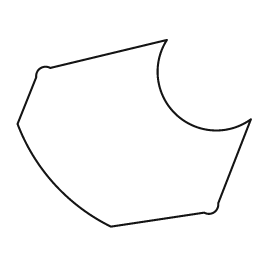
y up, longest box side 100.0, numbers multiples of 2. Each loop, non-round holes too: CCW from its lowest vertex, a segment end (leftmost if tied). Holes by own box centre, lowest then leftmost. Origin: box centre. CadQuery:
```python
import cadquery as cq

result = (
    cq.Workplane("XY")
    .moveTo(-10.0, -40.0)
    .lineTo(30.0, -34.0)
    .threePointArc((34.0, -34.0), (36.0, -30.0))
    .lineTo(50.0, 6.0)
    .threePointArc((18.0, 8.0), (14.0, 40.0))
    .lineTo(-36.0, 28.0)
    .threePointArc((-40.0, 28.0), (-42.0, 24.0))
    .lineTo(-50.0, 4.0)
    .threePointArc((-34.0, -22.0), (-10.0, -40.0))
    .close()
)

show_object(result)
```